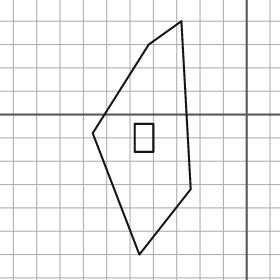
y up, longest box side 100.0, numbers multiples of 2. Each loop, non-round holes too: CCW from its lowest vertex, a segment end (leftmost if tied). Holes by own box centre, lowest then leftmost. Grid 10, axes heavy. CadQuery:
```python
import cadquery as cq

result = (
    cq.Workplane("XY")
    .moveTo(-46.0, -60.0)
    .lineTo(-24.0, -32.0)
    .lineTo(-28.0, 40.0)
    .lineTo(-42.0, 30.0)
    .lineTo(-66.0, -8.0)
    .close()
    .moveTo(-48.0, -16.0)
    .lineTo(-40.0, -16.0)
    .lineTo(-40.0, -4.0)
    .lineTo(-48.0, -4.0)
    .close()
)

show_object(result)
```